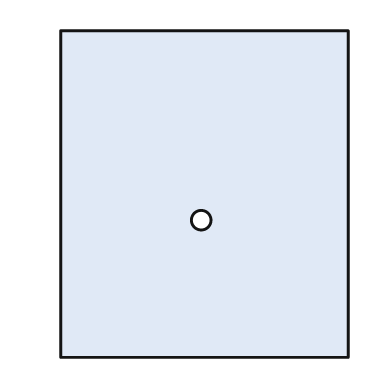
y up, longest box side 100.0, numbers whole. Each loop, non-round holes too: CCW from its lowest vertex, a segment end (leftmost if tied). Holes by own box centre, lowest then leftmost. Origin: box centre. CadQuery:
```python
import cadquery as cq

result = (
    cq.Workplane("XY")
    .moveTo(-44.0, -50.0)
    .lineTo(44.0, -50.0)
    .lineTo(44.0, 50.0)
    .lineTo(-44.0, 50.0)
    .close()
    .moveTo(-1.0, -8.0)
    .circle(3.0)
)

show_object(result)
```